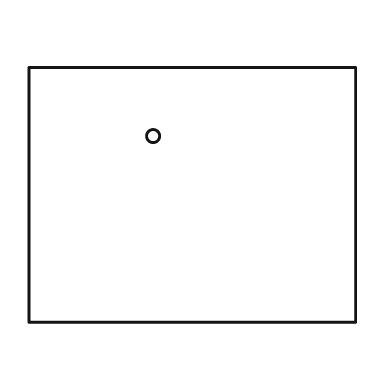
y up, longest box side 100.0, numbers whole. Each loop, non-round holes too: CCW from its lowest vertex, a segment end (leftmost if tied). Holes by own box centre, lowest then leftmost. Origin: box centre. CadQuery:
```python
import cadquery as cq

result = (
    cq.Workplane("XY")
    .moveTo(-50.0, -39.0)
    .lineTo(50.0, -39.0)
    .lineTo(50.0, 39.0)
    .lineTo(-50.0, 39.0)
    .close()
    .moveTo(-12.0, 18.0)
    .circle(2.0)
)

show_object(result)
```